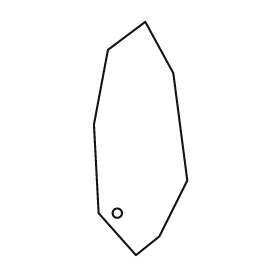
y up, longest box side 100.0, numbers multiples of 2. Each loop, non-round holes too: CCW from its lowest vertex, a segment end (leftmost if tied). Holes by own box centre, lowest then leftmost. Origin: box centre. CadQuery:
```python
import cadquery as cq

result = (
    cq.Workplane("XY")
    .moveTo(-2.0, -50.0)
    .lineTo(8.0, -42.0)
    .lineTo(20.0, -18.0)
    .lineTo(14.0, 28.0)
    .lineTo(2.0, 50.0)
    .lineTo(-14.0, 38.0)
    .lineTo(-20.0, 6.0)
    .lineTo(-18.0, -32.0)
    .close()
    .moveTo(-10.0, -32.0)
    .circle(2.0)
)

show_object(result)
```